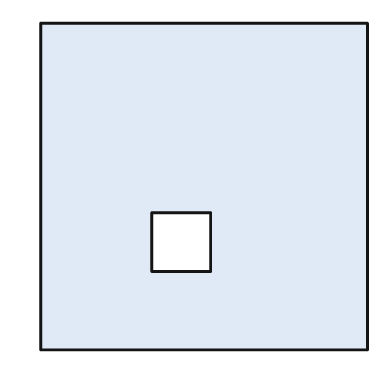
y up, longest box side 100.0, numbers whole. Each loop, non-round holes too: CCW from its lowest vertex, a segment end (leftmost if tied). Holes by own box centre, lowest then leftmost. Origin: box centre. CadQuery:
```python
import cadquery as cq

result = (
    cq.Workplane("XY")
    .moveTo(-50.0, -50.0)
    .lineTo(50.0, -50.0)
    .lineTo(50.0, 50.0)
    .lineTo(-50.0, 50.0)
    .close()
    .moveTo(-16.0, -26.0)
    .lineTo(2.0, -26.0)
    .lineTo(2.0, -8.0)
    .lineTo(-16.0, -8.0)
    .close()
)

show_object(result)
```